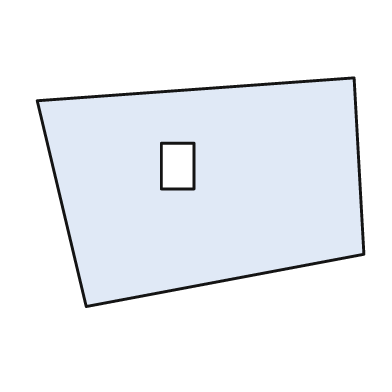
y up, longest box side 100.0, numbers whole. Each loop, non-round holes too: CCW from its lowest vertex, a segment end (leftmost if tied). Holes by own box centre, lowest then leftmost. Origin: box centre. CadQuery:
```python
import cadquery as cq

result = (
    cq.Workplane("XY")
    .moveTo(-35.0, -35.0)
    .lineTo(50.0, -19.0)
    .lineTo(47.0, 35.0)
    .lineTo(-50.0, 28.0)
    .close()
    .moveTo(-12.0, 1.0)
    .lineTo(-2.0, 1.0)
    .lineTo(-2.0, 15.0)
    .lineTo(-12.0, 15.0)
    .close()
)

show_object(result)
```